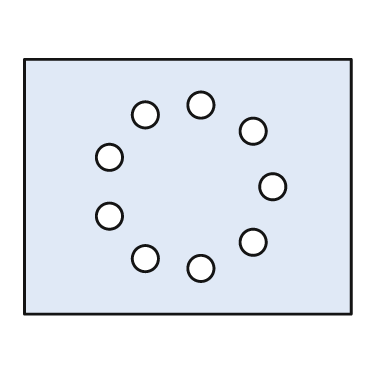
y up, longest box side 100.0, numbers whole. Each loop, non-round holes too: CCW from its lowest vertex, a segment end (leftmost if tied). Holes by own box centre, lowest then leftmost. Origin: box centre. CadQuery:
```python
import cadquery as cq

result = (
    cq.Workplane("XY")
    .moveTo(-50.0, -39.0)
    .lineTo(50.0, -39.0)
    .lineTo(50.0, 39.0)
    .lineTo(-50.0, 39.0)
    .close()
    .moveTo(4.0, -25.0)
    .circle(4.0)
    .moveTo(-13.0, -22.0)
    .circle(4.0)
    .moveTo(20.0, -17.0)
    .circle(4.0)
    .moveTo(-24.0, -9.0)
    .circle(4.0)
    .moveTo(26.0, 0.0)
    .circle(4.0)
    .moveTo(-24.0, 9.0)
    .circle(4.0)
    .moveTo(20.0, 17.0)
    .circle(4.0)
    .moveTo(-13.0, 22.0)
    .circle(4.0)
    .moveTo(4.0, 25.0)
    .circle(4.0)
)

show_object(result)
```